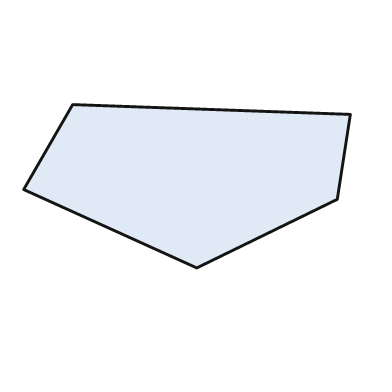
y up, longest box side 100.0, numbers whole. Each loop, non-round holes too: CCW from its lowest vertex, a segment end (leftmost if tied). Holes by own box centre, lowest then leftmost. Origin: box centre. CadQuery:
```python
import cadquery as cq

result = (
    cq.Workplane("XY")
    .moveTo(3.0, -25.0)
    .lineTo(46.0, -4.0)
    .lineTo(50.0, 22.0)
    .lineTo(-35.0, 25.0)
    .lineTo(-50.0, -1.0)
    .close()
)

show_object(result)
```